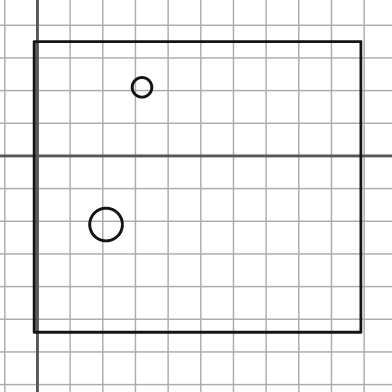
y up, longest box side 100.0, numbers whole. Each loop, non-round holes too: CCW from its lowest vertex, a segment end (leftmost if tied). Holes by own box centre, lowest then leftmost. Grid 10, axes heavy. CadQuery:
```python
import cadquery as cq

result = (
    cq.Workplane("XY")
    .moveTo(-1.0, -54.0)
    .lineTo(99.0, -54.0)
    .lineTo(99.0, 35.0)
    .lineTo(-1.0, 35.0)
    .close()
    .moveTo(21.0, -21.0)
    .circle(5.0)
    .moveTo(32.0, 21.0)
    .circle(3.0)
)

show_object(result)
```